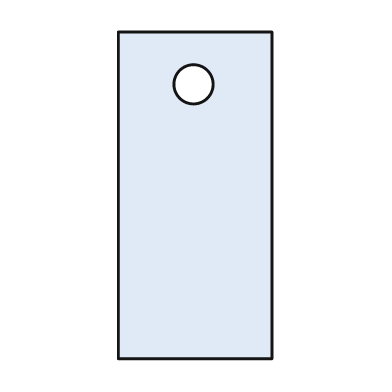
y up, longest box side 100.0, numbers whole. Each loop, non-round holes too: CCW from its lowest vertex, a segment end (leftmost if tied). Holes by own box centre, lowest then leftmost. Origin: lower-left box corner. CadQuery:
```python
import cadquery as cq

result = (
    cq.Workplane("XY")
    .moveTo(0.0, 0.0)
    .lineTo(47.0, 0.0)
    .lineTo(47.0, 100.0)
    .lineTo(0.0, 100.0)
    .close()
    .moveTo(23.0, 84.0)
    .circle(6.0)
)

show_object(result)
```